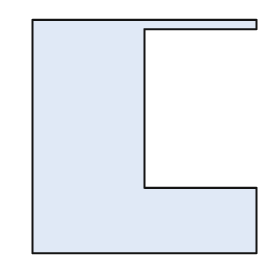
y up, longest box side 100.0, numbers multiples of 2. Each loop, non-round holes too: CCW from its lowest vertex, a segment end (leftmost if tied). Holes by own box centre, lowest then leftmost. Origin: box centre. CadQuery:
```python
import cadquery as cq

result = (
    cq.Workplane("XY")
    .moveTo(-48.0, -50.0)
    .lineTo(48.0, -50.0)
    .lineTo(48.0, -22.0)
    .lineTo(0.0, -22.0)
    .lineTo(0.0, 46.0)
    .lineTo(48.0, 46.0)
    .lineTo(48.0, 50.0)
    .lineTo(-48.0, 50.0)
    .close()
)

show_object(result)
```